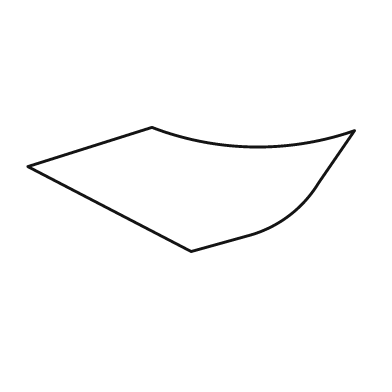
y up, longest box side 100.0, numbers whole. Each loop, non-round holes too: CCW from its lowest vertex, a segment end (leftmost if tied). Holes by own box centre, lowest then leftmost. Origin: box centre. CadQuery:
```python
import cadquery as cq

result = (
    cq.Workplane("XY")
    .moveTo(0.0, -19.0)
    .lineTo(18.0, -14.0)
    .threePointArc((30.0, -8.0), (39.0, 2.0))
    .lineTo(50.0, 18.0)
    .threePointArc((19.0, 13.0), (-12.0, 19.0))
    .lineTo(-50.0, 7.0)
    .close()
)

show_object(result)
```